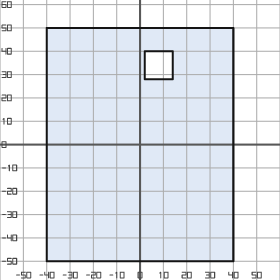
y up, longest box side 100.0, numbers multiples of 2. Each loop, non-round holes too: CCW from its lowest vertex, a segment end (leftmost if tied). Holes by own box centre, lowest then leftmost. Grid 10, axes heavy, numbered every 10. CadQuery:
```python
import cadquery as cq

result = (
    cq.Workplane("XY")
    .moveTo(-40.0, -50.0)
    .lineTo(40.0, -50.0)
    .lineTo(40.0, 50.0)
    .lineTo(-40.0, 50.0)
    .close()
    .moveTo(2.0, 28.0)
    .lineTo(14.0, 28.0)
    .lineTo(14.0, 40.0)
    .lineTo(2.0, 40.0)
    .close()
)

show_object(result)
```